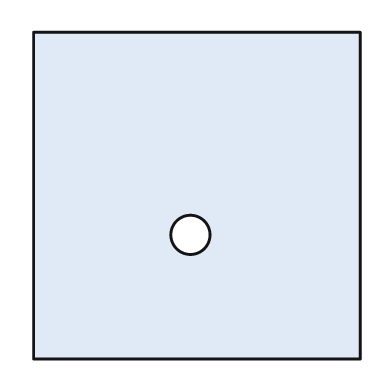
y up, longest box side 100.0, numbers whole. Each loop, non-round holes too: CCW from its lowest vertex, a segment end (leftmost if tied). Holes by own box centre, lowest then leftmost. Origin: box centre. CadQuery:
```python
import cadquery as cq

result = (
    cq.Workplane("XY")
    .moveTo(-50.0, -50.0)
    .lineTo(50.0, -50.0)
    .lineTo(50.0, 50.0)
    .lineTo(-50.0, 50.0)
    .close()
    .moveTo(-2.0, -12.0)
    .circle(6.0)
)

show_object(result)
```